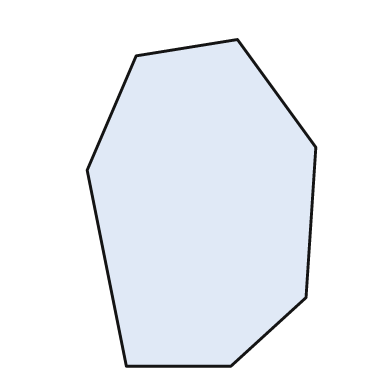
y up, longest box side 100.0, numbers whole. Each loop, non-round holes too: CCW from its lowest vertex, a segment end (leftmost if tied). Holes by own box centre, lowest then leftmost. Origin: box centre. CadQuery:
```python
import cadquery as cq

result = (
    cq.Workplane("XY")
    .moveTo(-23.0, -50.0)
    .lineTo(9.0, -50.0)
    .lineTo(32.0, -29.0)
    .lineTo(35.0, 17.0)
    .lineTo(11.0, 50.0)
    .lineTo(-20.0, 45.0)
    .lineTo(-35.0, 10.0)
    .close()
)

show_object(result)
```